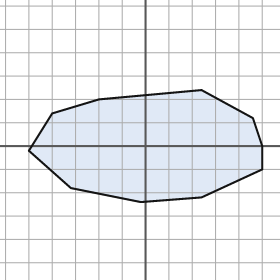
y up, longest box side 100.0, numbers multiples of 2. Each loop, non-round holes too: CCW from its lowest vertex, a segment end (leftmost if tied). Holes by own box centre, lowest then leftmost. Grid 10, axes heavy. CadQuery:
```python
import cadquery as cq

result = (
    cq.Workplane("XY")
    .moveTo(-2.0, -24.0)
    .lineTo(24.0, -22.0)
    .lineTo(50.0, -10.0)
    .lineTo(50.0, 0.0)
    .lineTo(46.0, 12.0)
    .lineTo(24.0, 24.0)
    .lineTo(-20.0, 20.0)
    .lineTo(-40.0, 14.0)
    .lineTo(-50.0, -2.0)
    .lineTo(-32.0, -18.0)
    .close()
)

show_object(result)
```